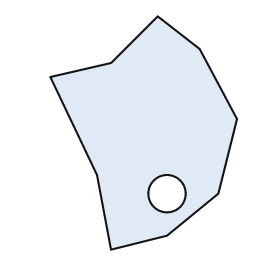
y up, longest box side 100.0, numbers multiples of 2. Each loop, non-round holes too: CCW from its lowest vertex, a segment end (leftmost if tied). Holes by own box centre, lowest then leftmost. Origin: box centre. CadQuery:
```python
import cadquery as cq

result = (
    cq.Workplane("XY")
    .moveTo(-14.0, -50.0)
    .lineTo(10.0, -44.0)
    .lineTo(32.0, -26.0)
    .lineTo(40.0, 6.0)
    .lineTo(24.0, 36.0)
    .lineTo(6.0, 50.0)
    .lineTo(-14.0, 30.0)
    .lineTo(-40.0, 24.0)
    .lineTo(-20.0, -18.0)
    .close()
    .moveTo(10.0, -26.0)
    .circle(8.0)
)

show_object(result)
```